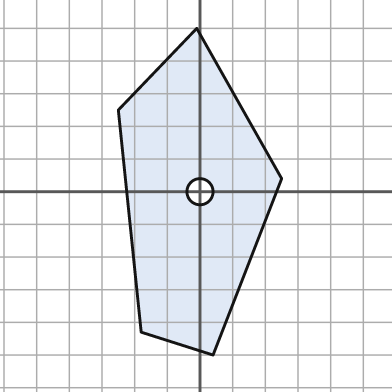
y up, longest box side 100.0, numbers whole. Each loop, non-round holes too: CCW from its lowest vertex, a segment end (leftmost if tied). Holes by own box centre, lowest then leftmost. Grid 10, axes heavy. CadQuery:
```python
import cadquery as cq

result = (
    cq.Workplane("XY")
    .moveTo(4.0, -50.0)
    .lineTo(25.0, 4.0)
    .lineTo(-1.0, 50.0)
    .lineTo(-25.0, 25.0)
    .lineTo(-18.0, -43.0)
    .close()
    .moveTo(0.0, 0.0)
    .circle(4.0)
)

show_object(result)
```